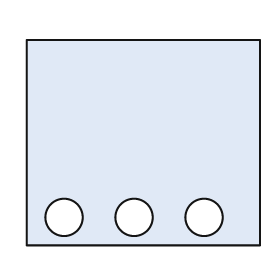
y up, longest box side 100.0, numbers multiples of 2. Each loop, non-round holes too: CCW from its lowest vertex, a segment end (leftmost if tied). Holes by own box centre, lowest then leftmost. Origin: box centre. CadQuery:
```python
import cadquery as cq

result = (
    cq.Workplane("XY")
    .moveTo(-50.0, -44.0)
    .lineTo(50.0, -44.0)
    .lineTo(50.0, 44.0)
    .lineTo(-50.0, 44.0)
    .close()
    .moveTo(-34.0, -32.0)
    .circle(8.0)
    .moveTo(-4.0, -32.0)
    .circle(8.0)
    .moveTo(26.0, -32.0)
    .circle(8.0)
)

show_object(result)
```